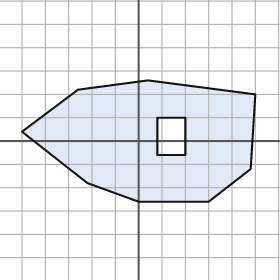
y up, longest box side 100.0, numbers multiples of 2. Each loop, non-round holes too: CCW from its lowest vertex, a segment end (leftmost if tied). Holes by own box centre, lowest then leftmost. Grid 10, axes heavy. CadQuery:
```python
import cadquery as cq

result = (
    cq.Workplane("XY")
    .moveTo(0.0, -26.0)
    .lineTo(30.0, -26.0)
    .lineTo(48.0, -12.0)
    .lineTo(50.0, 20.0)
    .lineTo(4.0, 26.0)
    .lineTo(-26.0, 22.0)
    .lineTo(-50.0, 4.0)
    .lineTo(-22.0, -18.0)
    .close()
    .moveTo(8.0, -6.0)
    .lineTo(20.0, -6.0)
    .lineTo(20.0, 10.0)
    .lineTo(8.0, 10.0)
    .close()
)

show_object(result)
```